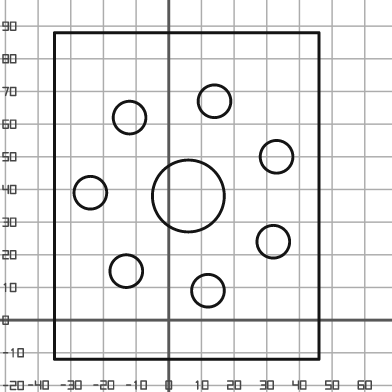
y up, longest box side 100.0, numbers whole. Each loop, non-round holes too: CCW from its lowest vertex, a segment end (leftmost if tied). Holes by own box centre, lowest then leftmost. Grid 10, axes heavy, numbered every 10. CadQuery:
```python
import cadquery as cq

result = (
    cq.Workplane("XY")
    .moveTo(-35.0, -12.0)
    .lineTo(46.0, -12.0)
    .lineTo(46.0, 88.0)
    .lineTo(-35.0, 88.0)
    .close()
    .moveTo(12.0, 9.0)
    .circle(5.0)
    .moveTo(-13.0, 15.0)
    .circle(5.0)
    .moveTo(32.0, 24.0)
    .circle(5.0)
    .moveTo(6.0, 38.0)
    .circle(11.0)
    .moveTo(-24.0, 39.0)
    .circle(5.0)
    .moveTo(33.0, 50.0)
    .circle(5.0)
    .moveTo(-12.0, 62.0)
    .circle(5.0)
    .moveTo(14.0, 67.0)
    .circle(5.0)
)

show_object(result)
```